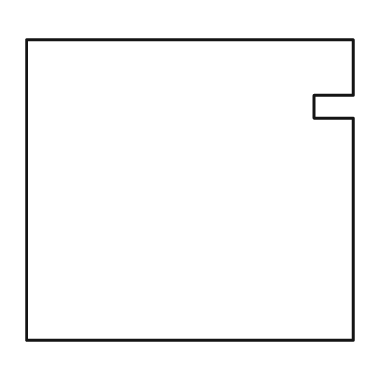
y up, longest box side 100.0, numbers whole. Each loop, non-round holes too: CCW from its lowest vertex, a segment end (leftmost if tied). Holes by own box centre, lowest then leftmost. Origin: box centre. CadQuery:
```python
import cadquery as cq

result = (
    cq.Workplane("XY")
    .moveTo(-50.0, -46.0)
    .lineTo(50.0, -46.0)
    .lineTo(50.0, 22.0)
    .lineTo(38.0, 22.0)
    .lineTo(38.0, 29.0)
    .lineTo(50.0, 29.0)
    .lineTo(50.0, 46.0)
    .lineTo(-50.0, 46.0)
    .close()
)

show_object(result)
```